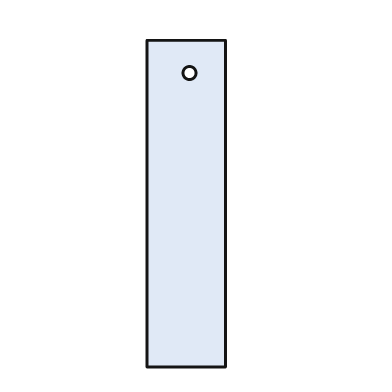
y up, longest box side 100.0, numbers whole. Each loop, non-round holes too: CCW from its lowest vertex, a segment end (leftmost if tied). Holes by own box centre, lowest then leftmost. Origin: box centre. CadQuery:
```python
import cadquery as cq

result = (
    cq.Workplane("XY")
    .moveTo(-12.0, -50.0)
    .lineTo(12.0, -50.0)
    .lineTo(12.0, 50.0)
    .lineTo(-12.0, 50.0)
    .close()
    .moveTo(1.0, 40.0)
    .circle(2.0)
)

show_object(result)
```